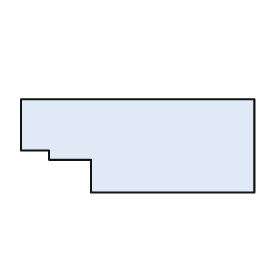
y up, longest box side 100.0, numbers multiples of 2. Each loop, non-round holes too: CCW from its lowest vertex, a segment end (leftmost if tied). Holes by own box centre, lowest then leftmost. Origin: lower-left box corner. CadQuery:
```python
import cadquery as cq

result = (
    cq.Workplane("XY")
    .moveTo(30.0, 0.0)
    .lineTo(100.0, 0.0)
    .lineTo(100.0, 40.0)
    .lineTo(0.0, 40.0)
    .lineTo(0.0, 18.0)
    .lineTo(12.0, 18.0)
    .lineTo(12.0, 14.0)
    .lineTo(30.0, 14.0)
    .close()
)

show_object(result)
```